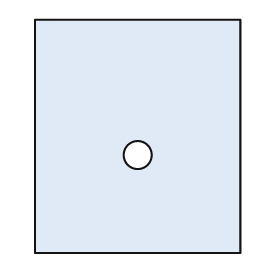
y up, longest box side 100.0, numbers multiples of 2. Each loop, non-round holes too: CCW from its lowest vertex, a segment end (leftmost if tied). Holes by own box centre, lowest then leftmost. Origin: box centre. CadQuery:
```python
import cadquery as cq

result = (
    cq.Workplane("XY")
    .moveTo(-44.0, -50.0)
    .lineTo(44.0, -50.0)
    .lineTo(44.0, 50.0)
    .lineTo(-44.0, 50.0)
    .close()
    .moveTo(0.0, -8.0)
    .circle(6.0)
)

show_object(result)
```